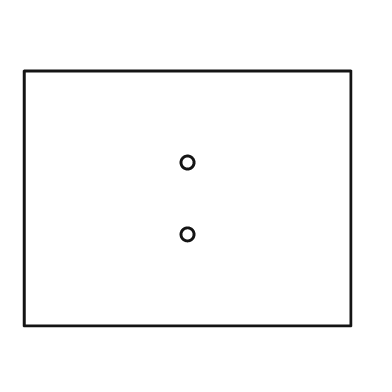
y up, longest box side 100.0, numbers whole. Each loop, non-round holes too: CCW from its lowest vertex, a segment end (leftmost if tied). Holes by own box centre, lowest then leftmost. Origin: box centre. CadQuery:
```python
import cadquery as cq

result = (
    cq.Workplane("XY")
    .moveTo(-50.0, -39.0)
    .lineTo(50.0, -39.0)
    .lineTo(50.0, 39.0)
    .lineTo(-50.0, 39.0)
    .close()
    .moveTo(0.0, -11.0)
    .circle(2.0)
    .moveTo(0.0, 11.0)
    .circle(2.0)
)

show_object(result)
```